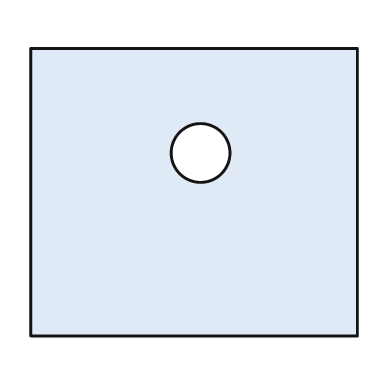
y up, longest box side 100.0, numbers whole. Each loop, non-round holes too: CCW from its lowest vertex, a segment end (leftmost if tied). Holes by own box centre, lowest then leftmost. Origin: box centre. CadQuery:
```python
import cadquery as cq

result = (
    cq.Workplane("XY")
    .moveTo(-50.0, -44.0)
    .lineTo(50.0, -44.0)
    .lineTo(50.0, 44.0)
    .lineTo(-50.0, 44.0)
    .close()
    .moveTo(2.0, 12.0)
    .circle(9.0)
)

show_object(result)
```